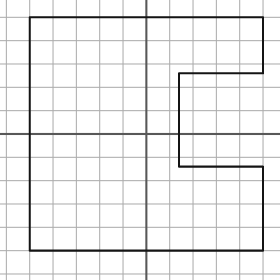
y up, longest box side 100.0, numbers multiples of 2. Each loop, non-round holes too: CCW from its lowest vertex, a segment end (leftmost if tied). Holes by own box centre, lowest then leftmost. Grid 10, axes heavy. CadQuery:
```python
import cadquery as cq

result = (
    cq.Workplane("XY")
    .moveTo(-50.0, -50.0)
    .lineTo(50.0, -50.0)
    .lineTo(50.0, -14.0)
    .lineTo(14.0, -14.0)
    .lineTo(14.0, 26.0)
    .lineTo(50.0, 26.0)
    .lineTo(50.0, 50.0)
    .lineTo(-50.0, 50.0)
    .close()
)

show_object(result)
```